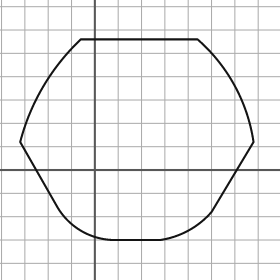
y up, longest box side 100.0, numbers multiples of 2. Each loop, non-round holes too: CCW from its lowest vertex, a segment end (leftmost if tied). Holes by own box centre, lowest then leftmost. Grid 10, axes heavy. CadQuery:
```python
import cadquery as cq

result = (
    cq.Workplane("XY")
    .moveTo(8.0, -30.0)
    .lineTo(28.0, -30.0)
    .threePointArc((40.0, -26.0), (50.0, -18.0))
    .lineTo(68.0, 12.0)
    .threePointArc((60.0, 36.0), (44.0, 56.0))
    .lineTo(-6.0, 56.0)
    .threePointArc((-22.0, 36.0), (-32.0, 12.0))
    .lineTo(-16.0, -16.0)
    .threePointArc((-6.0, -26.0), (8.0, -30.0))
    .close()
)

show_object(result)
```